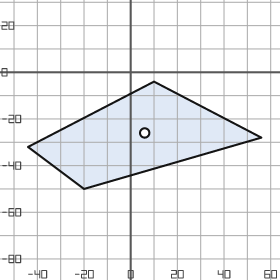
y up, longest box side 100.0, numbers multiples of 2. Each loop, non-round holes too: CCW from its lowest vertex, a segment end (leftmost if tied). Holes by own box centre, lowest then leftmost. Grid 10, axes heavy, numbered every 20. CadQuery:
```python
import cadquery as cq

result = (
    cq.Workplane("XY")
    .moveTo(-20.0, -50.0)
    .lineTo(56.0, -28.0)
    .lineTo(10.0, -4.0)
    .lineTo(-44.0, -32.0)
    .close()
    .moveTo(6.0, -26.0)
    .circle(2.0)
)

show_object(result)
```